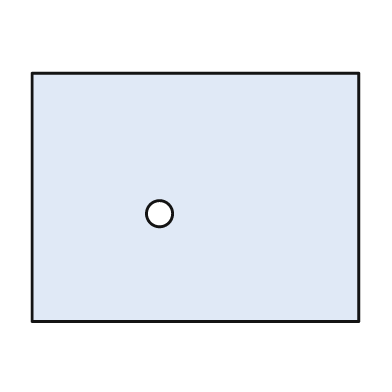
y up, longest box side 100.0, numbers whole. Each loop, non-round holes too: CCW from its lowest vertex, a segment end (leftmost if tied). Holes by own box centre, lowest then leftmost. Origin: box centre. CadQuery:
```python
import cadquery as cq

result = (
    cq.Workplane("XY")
    .moveTo(-50.0, -38.0)
    .lineTo(50.0, -38.0)
    .lineTo(50.0, 38.0)
    .lineTo(-50.0, 38.0)
    .close()
    .moveTo(-11.0, -5.0)
    .circle(4.0)
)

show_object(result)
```